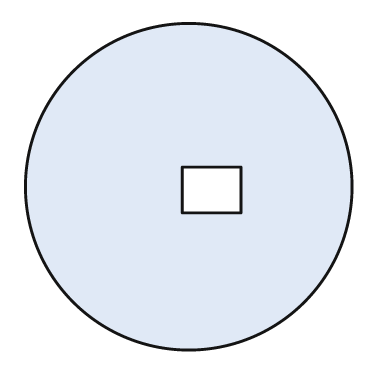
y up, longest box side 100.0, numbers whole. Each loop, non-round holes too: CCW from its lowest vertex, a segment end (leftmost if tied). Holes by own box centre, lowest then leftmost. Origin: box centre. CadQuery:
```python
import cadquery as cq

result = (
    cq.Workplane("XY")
    .moveTo(0.0, 0.0)
    .circle(50.0)
    .moveTo(-2.0, -8.0)
    .lineTo(16.0, -8.0)
    .lineTo(16.0, 6.0)
    .lineTo(-2.0, 6.0)
    .close()
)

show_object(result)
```